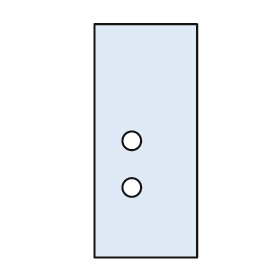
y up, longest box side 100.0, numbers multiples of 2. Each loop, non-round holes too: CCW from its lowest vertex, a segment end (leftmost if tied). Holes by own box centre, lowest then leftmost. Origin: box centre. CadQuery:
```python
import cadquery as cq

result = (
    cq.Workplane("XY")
    .moveTo(-22.0, -50.0)
    .lineTo(22.0, -50.0)
    .lineTo(22.0, 50.0)
    .lineTo(-22.0, 50.0)
    .close()
    .moveTo(-6.0, -20.0)
    .circle(4.0)
    .moveTo(-6.0, 0.0)
    .circle(4.0)
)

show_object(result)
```